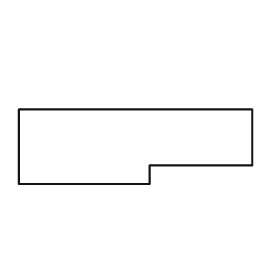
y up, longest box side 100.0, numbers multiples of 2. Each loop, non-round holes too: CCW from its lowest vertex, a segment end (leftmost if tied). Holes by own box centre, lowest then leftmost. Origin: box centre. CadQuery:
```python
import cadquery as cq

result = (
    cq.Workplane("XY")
    .moveTo(-50.0, -16.0)
    .lineTo(6.0, -16.0)
    .lineTo(6.0, -8.0)
    .lineTo(50.0, -8.0)
    .lineTo(50.0, 16.0)
    .lineTo(-50.0, 16.0)
    .close()
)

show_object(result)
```